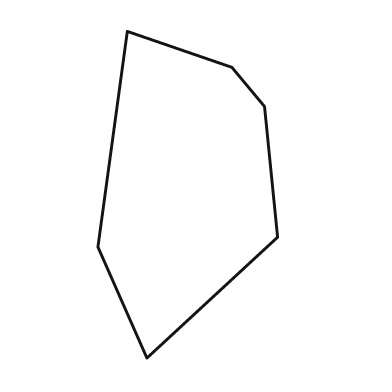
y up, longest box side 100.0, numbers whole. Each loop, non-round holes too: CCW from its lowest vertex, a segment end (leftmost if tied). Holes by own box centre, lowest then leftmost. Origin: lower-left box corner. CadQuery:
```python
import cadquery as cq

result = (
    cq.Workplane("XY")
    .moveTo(15.0, 0.0)
    .lineTo(55.0, 37.0)
    .lineTo(51.0, 77.0)
    .lineTo(41.0, 89.0)
    .lineTo(9.0, 100.0)
    .lineTo(0.0, 34.0)
    .close()
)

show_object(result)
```